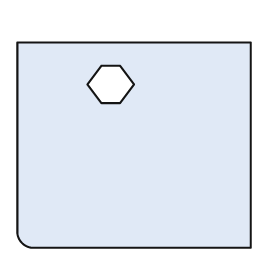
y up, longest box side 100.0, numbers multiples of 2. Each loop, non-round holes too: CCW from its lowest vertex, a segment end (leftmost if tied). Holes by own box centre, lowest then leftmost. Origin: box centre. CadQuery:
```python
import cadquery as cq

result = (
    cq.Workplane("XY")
    .moveTo(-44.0, -44.0)
    .lineTo(50.0, -44.0)
    .lineTo(50.0, 44.0)
    .lineTo(-50.0, 44.0)
    .lineTo(-50.0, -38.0)
    .threePointArc((-48.0, -42.0), (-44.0, -44.0))
    .close()
    .moveTo(-14.0, 18.0)
    .lineTo(-6.0, 18.0)
    .lineTo(0.0, 26.0)
    .lineTo(-6.0, 34.0)
    .lineTo(-14.0, 34.0)
    .lineTo(-20.0, 26.0)
    .close()
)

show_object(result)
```